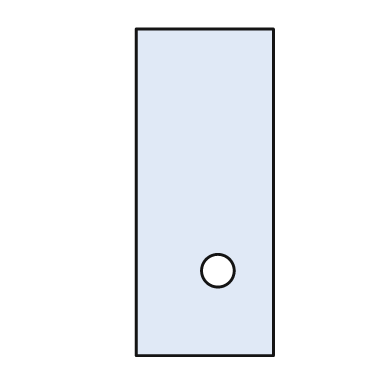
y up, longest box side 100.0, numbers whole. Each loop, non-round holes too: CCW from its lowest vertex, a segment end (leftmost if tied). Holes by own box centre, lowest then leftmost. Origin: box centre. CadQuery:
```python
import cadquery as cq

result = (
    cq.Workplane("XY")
    .moveTo(-21.0, -50.0)
    .lineTo(21.0, -50.0)
    .lineTo(21.0, 50.0)
    .lineTo(-21.0, 50.0)
    .close()
    .moveTo(4.0, -24.0)
    .circle(5.0)
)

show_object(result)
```